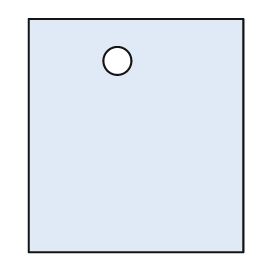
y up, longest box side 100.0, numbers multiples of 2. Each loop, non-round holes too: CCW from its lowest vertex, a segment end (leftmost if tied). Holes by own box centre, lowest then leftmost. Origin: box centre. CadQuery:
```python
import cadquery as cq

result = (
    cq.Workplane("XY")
    .moveTo(-46.0, -50.0)
    .lineTo(46.0, -50.0)
    .lineTo(46.0, 50.0)
    .lineTo(-46.0, 50.0)
    .close()
    .moveTo(-8.0, 32.0)
    .circle(6.0)
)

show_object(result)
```